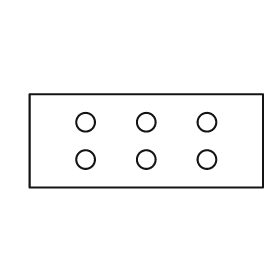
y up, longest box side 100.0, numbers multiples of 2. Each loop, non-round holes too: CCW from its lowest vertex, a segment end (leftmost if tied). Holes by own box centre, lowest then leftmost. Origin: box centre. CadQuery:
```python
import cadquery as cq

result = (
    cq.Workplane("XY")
    .moveTo(-50.0, -20.0)
    .lineTo(50.0, -20.0)
    .lineTo(50.0, 20.0)
    .lineTo(-50.0, 20.0)
    .close()
    .moveTo(-26.0, -8.0)
    .circle(4.0)
    .moveTo(0.0, -8.0)
    .circle(4.0)
    .moveTo(26.0, -8.0)
    .circle(4.0)
    .moveTo(-26.0, 8.0)
    .circle(4.0)
    .moveTo(0.0, 8.0)
    .circle(4.0)
    .moveTo(26.0, 8.0)
    .circle(4.0)
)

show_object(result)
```